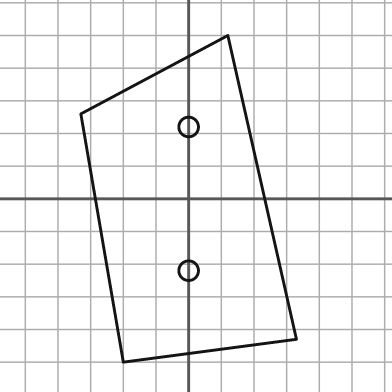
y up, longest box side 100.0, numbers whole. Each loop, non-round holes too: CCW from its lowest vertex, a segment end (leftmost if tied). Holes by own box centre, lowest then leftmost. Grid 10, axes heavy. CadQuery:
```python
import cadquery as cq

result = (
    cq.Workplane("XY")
    .moveTo(-20.0, -50.0)
    .lineTo(33.0, -43.0)
    .lineTo(12.0, 50.0)
    .lineTo(-33.0, 26.0)
    .close()
    .moveTo(0.0, -22.0)
    .circle(3.0)
    .moveTo(0.0, 22.0)
    .circle(3.0)
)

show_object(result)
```